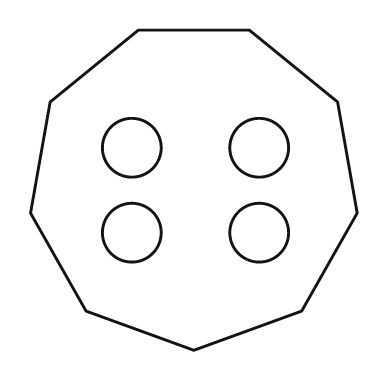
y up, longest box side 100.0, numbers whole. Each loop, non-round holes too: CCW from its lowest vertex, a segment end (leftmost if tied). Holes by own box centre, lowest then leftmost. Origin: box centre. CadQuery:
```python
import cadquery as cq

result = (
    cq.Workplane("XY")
    .moveTo(0.0, -49.0)
    .lineTo(33.0, -37.0)
    .lineTo(50.0, -7.0)
    .lineTo(44.0, 27.0)
    .lineTo(17.0, 49.0)
    .lineTo(-17.0, 49.0)
    .lineTo(-44.0, 27.0)
    .lineTo(-50.0, -7.0)
    .lineTo(-33.0, -37.0)
    .close()
    .moveTo(-19.0, -13.0)
    .circle(9.0)
    .moveTo(20.0, -13.0)
    .circle(9.0)
    .moveTo(-19.0, 13.0)
    .circle(9.0)
    .moveTo(20.0, 13.0)
    .circle(9.0)
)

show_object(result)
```